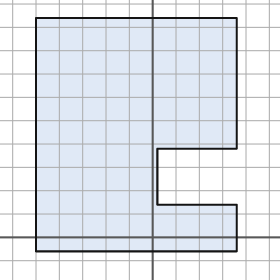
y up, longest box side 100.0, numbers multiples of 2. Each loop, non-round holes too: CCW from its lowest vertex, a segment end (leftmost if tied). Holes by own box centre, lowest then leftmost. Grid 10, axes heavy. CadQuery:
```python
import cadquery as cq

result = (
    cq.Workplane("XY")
    .moveTo(-50.0, -6.0)
    .lineTo(36.0, -6.0)
    .lineTo(36.0, 14.0)
    .lineTo(2.0, 14.0)
    .lineTo(2.0, 38.0)
    .lineTo(36.0, 38.0)
    .lineTo(36.0, 94.0)
    .lineTo(-50.0, 94.0)
    .close()
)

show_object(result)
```